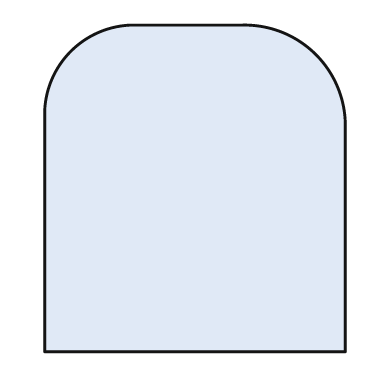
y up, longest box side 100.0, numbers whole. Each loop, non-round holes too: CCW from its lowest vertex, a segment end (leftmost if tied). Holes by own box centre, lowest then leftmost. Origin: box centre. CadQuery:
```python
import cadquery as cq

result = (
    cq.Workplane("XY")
    .moveTo(-46.0, -50.0)
    .lineTo(46.0, -50.0)
    .lineTo(46.0, 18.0)
    .threePointArc((37.0, 41.0), (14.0, 50.0))
    .lineTo(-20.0, 50.0)
    .threePointArc((-38.0, 42.0), (-46.0, 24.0))
    .close()
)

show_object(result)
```